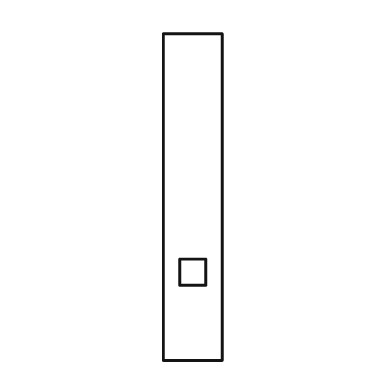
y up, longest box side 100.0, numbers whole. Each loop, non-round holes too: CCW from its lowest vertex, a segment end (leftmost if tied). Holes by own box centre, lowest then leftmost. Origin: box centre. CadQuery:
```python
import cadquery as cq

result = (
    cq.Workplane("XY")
    .moveTo(-9.0, -50.0)
    .lineTo(9.0, -50.0)
    .lineTo(9.0, 50.0)
    .lineTo(-9.0, 50.0)
    .close()
    .moveTo(-4.0, -27.0)
    .lineTo(4.0, -27.0)
    .lineTo(4.0, -19.0)
    .lineTo(-4.0, -19.0)
    .close()
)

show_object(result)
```